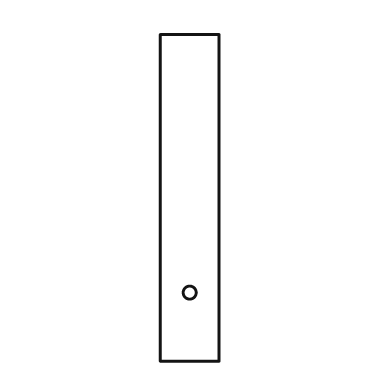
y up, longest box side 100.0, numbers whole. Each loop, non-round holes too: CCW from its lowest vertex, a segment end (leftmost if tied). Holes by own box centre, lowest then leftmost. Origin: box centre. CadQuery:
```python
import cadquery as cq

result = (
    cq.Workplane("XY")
    .moveTo(-9.0, -50.0)
    .lineTo(9.0, -50.0)
    .lineTo(9.0, 50.0)
    .lineTo(-9.0, 50.0)
    .close()
    .moveTo(0.0, -29.0)
    .circle(2.0)
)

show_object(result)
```